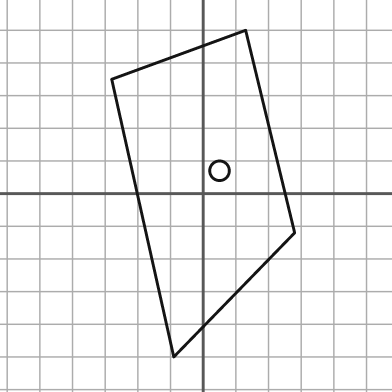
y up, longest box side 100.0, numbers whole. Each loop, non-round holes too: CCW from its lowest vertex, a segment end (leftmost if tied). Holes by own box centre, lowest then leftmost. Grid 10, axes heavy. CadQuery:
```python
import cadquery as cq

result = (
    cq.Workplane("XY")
    .moveTo(-9.0, -50.0)
    .lineTo(28.0, -12.0)
    .lineTo(13.0, 50.0)
    .lineTo(-28.0, 35.0)
    .close()
    .moveTo(5.0, 7.0)
    .circle(3.0)
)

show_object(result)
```